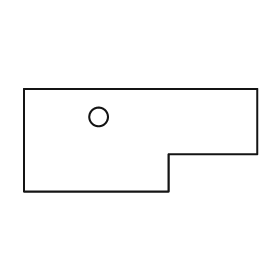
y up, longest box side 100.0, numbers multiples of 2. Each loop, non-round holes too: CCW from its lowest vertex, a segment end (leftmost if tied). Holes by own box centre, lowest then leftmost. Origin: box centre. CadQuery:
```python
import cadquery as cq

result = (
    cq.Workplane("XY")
    .moveTo(-50.0, -22.0)
    .lineTo(12.0, -22.0)
    .lineTo(12.0, -6.0)
    .lineTo(50.0, -6.0)
    .lineTo(50.0, 22.0)
    .lineTo(-50.0, 22.0)
    .close()
    .moveTo(-18.0, 10.0)
    .circle(4.0)
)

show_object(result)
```